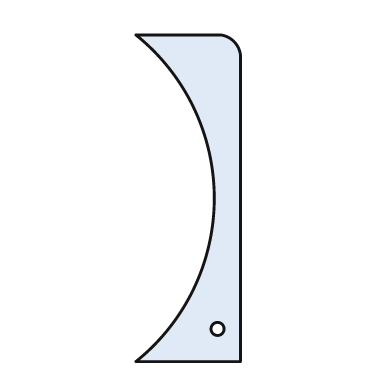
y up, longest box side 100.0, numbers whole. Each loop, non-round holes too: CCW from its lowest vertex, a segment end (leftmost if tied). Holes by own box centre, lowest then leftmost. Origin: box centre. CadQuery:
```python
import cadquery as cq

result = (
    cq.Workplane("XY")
    .moveTo(-16.0, -50.0)
    .lineTo(16.0, -50.0)
    .lineTo(16.0, 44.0)
    .threePointArc((14.0, 48.0), (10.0, 50.0))
    .lineTo(-16.0, 50.0)
    .threePointArc((8.0, 0.0), (-16.0, -50.0))
    .close()
    .moveTo(9.0, -40.0)
    .circle(2.0)
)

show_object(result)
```